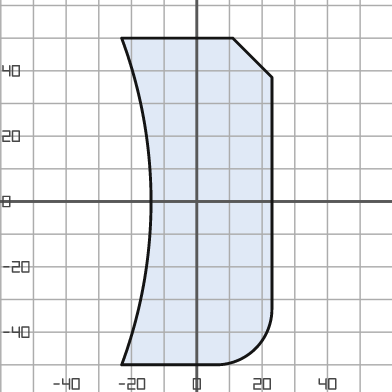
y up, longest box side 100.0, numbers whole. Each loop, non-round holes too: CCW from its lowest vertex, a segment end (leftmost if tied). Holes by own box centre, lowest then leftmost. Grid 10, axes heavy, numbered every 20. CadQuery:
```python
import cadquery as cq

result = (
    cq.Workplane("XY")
    .moveTo(-23.0, -50.0)
    .lineTo(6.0, -50.0)
    .threePointArc((18.0, -45.0), (23.0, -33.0))
    .lineTo(23.0, 38.0)
    .lineTo(11.0, 50.0)
    .lineTo(-23.0, 50.0)
    .threePointArc((-14.0, 0.0), (-23.0, -50.0))
    .close()
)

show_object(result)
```